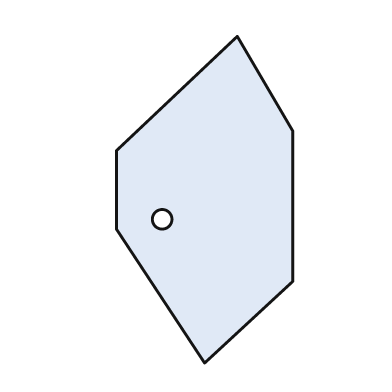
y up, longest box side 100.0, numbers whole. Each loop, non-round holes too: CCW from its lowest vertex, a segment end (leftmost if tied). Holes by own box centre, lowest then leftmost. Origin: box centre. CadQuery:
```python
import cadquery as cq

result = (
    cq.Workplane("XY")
    .moveTo(0.0, -50.0)
    .lineTo(27.0, -25.0)
    .lineTo(27.0, 21.0)
    .lineTo(10.0, 50.0)
    .lineTo(-27.0, 15.0)
    .lineTo(-27.0, -9.0)
    .close()
    .moveTo(-13.0, -6.0)
    .circle(3.0)
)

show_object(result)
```